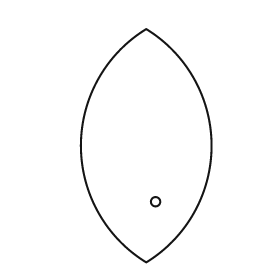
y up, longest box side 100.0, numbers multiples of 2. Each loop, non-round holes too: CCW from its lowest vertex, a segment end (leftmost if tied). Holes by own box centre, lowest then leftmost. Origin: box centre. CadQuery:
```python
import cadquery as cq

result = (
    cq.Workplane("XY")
    .moveTo(0.0, -50.0)
    .threePointArc((28.0, 0.0), (0.0, 50.0))
    .threePointArc((-28.0, 0.0), (0.0, -50.0))
    .close()
    .moveTo(4.0, -24.0)
    .circle(2.0)
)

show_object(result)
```